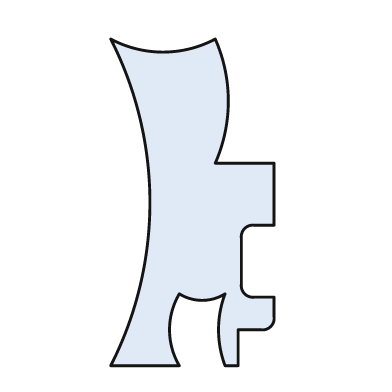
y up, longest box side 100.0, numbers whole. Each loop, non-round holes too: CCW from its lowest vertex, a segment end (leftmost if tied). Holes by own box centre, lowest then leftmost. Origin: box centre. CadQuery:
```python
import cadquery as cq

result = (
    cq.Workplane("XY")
    .moveTo(-25.0, -50.0)
    .lineTo(-4.0, -50.0)
    .threePointArc((-7.0, -39.0), (-4.0, -28.0))
    .threePointArc((3.0, -30.0), (10.0, -28.0))
    .threePointArc((8.0, -39.0), (10.0, -50.0))
    .lineTo(14.0, -50.0)
    .lineTo(14.0, -39.0)
    .lineTo(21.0, -39.0)
    .threePointArc((24.0, -38.0), (25.0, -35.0))
    .lineTo(25.0, -29.0)
    .lineTo(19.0, -29.0)
    .threePointArc((16.0, -28.0), (15.0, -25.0))
    .lineTo(15.0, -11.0)
    .threePointArc((16.0, -8.0), (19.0, -7.0))
    .lineTo(25.0, -7.0)
    .lineTo(25.0, 12.0)
    .lineTo(7.0, 12.0)
    .threePointArc((11.0, 31.0), (7.0, 50.0))
    .threePointArc((-9.0, 46.0), (-25.0, 50.0))
    .threePointArc((-13.0, 0.0), (-25.0, -50.0))
    .close()
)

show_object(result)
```